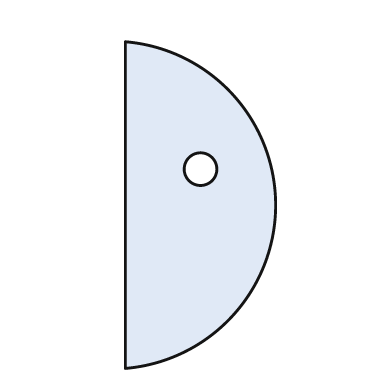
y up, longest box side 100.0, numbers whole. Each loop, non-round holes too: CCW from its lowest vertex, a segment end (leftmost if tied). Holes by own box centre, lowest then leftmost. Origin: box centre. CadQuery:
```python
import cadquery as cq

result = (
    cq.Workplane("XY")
    .moveTo(-23.0, -50.0)
    .threePointArc((23.0, 0.0), (-23.0, 50.0))
    .close()
    .moveTo(0.0, 11.0)
    .circle(5.0)
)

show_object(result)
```